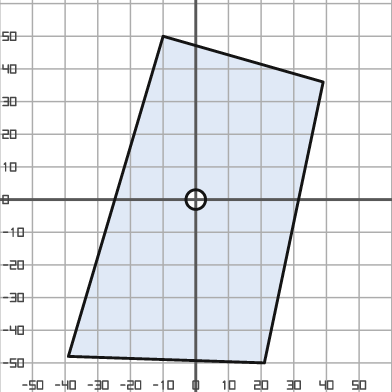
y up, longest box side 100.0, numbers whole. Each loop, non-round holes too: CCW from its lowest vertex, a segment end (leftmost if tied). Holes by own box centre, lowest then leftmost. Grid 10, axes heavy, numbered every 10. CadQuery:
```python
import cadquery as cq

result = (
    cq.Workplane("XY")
    .moveTo(21.0, -50.0)
    .lineTo(39.0, 36.0)
    .lineTo(-10.0, 50.0)
    .lineTo(-39.0, -48.0)
    .close()
    .moveTo(0.0, 0.0)
    .circle(3.0)
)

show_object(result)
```